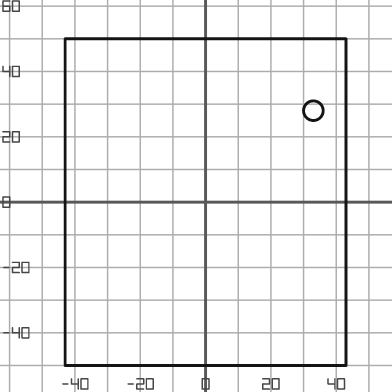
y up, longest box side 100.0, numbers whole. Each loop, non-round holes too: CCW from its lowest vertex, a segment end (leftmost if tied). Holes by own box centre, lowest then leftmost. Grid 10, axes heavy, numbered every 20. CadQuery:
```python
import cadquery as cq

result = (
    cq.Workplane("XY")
    .moveTo(-43.0, -50.0)
    .lineTo(43.0, -50.0)
    .lineTo(43.0, 50.0)
    .lineTo(-43.0, 50.0)
    .close()
    .moveTo(33.0, 28.0)
    .circle(3.0)
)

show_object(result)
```